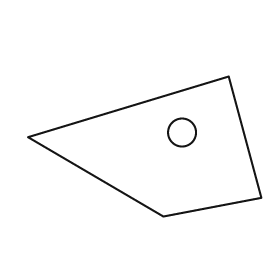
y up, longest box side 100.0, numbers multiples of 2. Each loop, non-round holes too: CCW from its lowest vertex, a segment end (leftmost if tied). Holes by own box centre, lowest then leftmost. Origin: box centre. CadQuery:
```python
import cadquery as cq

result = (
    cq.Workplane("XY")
    .moveTo(8.0, -30.0)
    .lineTo(50.0, -22.0)
    .lineTo(36.0, 30.0)
    .lineTo(-50.0, 4.0)
    .close()
    .moveTo(16.0, 6.0)
    .circle(6.0)
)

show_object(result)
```